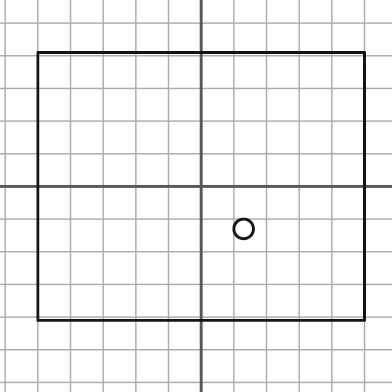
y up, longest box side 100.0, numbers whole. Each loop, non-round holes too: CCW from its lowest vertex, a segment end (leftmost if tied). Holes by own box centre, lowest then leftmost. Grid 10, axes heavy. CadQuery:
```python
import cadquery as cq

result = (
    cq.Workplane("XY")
    .moveTo(-50.0, -41.0)
    .lineTo(50.0, -41.0)
    .lineTo(50.0, 41.0)
    .lineTo(-50.0, 41.0)
    .close()
    .moveTo(13.0, -13.0)
    .circle(3.0)
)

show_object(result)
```